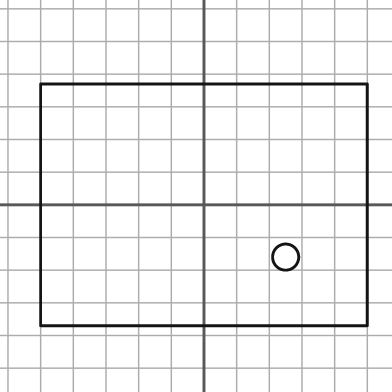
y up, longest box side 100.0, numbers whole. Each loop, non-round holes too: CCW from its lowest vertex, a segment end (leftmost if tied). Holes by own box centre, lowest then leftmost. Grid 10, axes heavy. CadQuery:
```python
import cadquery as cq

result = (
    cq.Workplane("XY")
    .moveTo(-50.0, -37.0)
    .lineTo(50.0, -37.0)
    .lineTo(50.0, 37.0)
    .lineTo(-50.0, 37.0)
    .close()
    .moveTo(25.0, -16.0)
    .circle(4.0)
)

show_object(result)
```